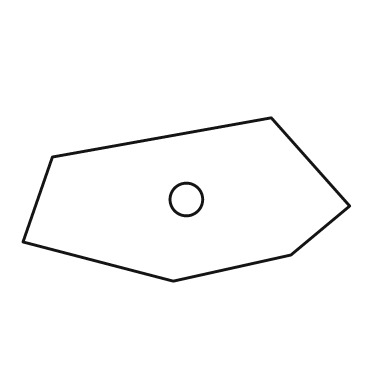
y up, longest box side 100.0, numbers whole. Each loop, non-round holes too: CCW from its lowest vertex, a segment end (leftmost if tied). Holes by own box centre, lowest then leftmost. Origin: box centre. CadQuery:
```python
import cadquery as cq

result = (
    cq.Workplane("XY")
    .moveTo(-4.0, -25.0)
    .lineTo(32.0, -17.0)
    .lineTo(50.0, -2.0)
    .lineTo(26.0, 25.0)
    .lineTo(-41.0, 13.0)
    .lineTo(-50.0, -13.0)
    .close()
    .moveTo(0.0, 0.0)
    .circle(5.0)
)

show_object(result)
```